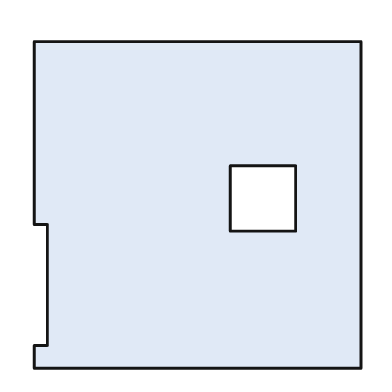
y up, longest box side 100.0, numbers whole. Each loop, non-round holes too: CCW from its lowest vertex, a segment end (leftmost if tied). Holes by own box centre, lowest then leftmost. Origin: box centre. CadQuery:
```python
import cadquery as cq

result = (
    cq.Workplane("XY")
    .moveTo(-50.0, -50.0)
    .lineTo(50.0, -50.0)
    .lineTo(50.0, 50.0)
    .lineTo(-50.0, 50.0)
    .lineTo(-50.0, -6.0)
    .lineTo(-46.0, -6.0)
    .lineTo(-46.0, -43.0)
    .lineTo(-50.0, -43.0)
    .close()
    .moveTo(10.0, -8.0)
    .lineTo(30.0, -8.0)
    .lineTo(30.0, 12.0)
    .lineTo(10.0, 12.0)
    .close()
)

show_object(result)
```